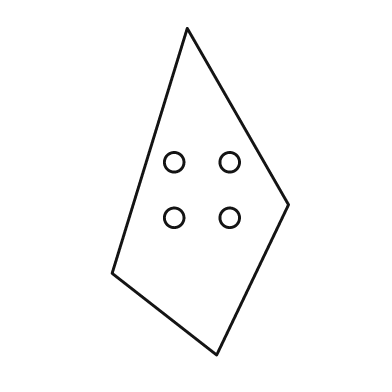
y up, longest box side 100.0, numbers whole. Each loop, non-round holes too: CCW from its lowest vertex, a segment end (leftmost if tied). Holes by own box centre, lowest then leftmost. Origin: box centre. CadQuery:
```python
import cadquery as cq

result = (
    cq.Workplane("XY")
    .moveTo(5.0, -50.0)
    .lineTo(27.0, -4.0)
    .lineTo(-4.0, 50.0)
    .lineTo(-27.0, -25.0)
    .close()
    .moveTo(-8.0, -8.0)
    .circle(3.0)
    .moveTo(9.0, -8.0)
    .circle(3.0)
    .moveTo(-8.0, 9.0)
    .circle(3.0)
    .moveTo(9.0, 9.0)
    .circle(3.0)
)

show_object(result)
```